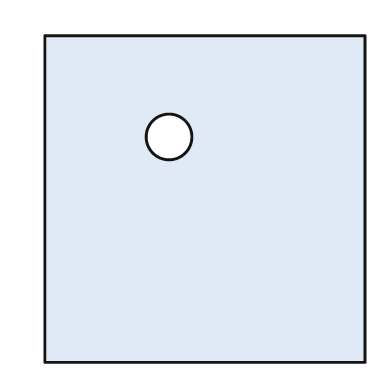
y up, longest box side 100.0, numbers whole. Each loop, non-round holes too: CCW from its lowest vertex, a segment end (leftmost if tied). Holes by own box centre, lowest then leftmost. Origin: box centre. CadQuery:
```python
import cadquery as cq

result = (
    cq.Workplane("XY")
    .moveTo(-49.0, -50.0)
    .lineTo(49.0, -50.0)
    .lineTo(49.0, 50.0)
    .lineTo(-49.0, 50.0)
    .close()
    .moveTo(-11.0, 19.0)
    .circle(7.0)
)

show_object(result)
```